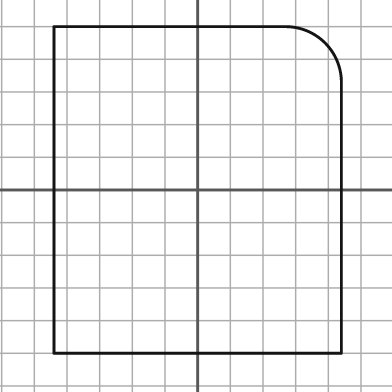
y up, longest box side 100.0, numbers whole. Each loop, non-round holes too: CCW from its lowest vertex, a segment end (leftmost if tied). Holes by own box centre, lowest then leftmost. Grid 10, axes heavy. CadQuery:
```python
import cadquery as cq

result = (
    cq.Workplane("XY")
    .moveTo(-44.0, -50.0)
    .lineTo(44.0, -50.0)
    .lineTo(44.0, 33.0)
    .threePointArc((39.0, 45.0), (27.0, 50.0))
    .lineTo(-44.0, 50.0)
    .close()
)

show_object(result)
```